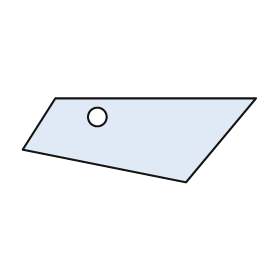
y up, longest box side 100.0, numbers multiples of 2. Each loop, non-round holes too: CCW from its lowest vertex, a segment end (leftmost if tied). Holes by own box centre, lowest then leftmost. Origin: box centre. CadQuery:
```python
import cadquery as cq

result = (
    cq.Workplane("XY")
    .moveTo(20.0, -18.0)
    .lineTo(50.0, 18.0)
    .lineTo(-36.0, 18.0)
    .lineTo(-50.0, -4.0)
    .close()
    .moveTo(-18.0, 10.0)
    .circle(4.0)
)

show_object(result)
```